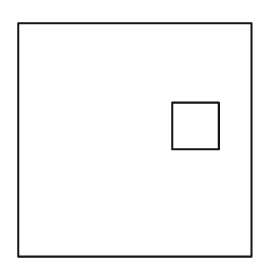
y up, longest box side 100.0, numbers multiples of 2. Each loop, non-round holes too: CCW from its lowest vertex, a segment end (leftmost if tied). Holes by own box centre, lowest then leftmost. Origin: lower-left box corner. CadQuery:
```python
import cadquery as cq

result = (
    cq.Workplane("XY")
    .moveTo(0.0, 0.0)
    .lineTo(100.0, 0.0)
    .lineTo(100.0, 100.0)
    .lineTo(0.0, 100.0)
    .close()
    .moveTo(66.0, 46.0)
    .lineTo(86.0, 46.0)
    .lineTo(86.0, 66.0)
    .lineTo(66.0, 66.0)
    .close()
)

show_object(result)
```